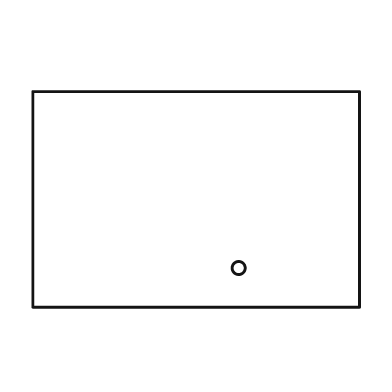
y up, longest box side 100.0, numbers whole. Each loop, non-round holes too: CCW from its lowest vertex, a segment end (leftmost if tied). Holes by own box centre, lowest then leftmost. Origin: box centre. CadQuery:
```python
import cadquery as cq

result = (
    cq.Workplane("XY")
    .moveTo(-50.0, -33.0)
    .lineTo(50.0, -33.0)
    .lineTo(50.0, 33.0)
    .lineTo(-50.0, 33.0)
    .close()
    .moveTo(13.0, -21.0)
    .circle(2.0)
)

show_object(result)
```